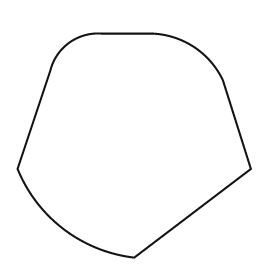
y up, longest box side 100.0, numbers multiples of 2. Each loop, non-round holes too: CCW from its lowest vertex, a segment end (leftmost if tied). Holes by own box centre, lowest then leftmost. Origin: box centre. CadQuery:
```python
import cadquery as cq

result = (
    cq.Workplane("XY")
    .moveTo(0.0, -48.0)
    .lineTo(50.0, -10.0)
    .lineTo(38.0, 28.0)
    .threePointArc((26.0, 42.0), (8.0, 48.0))
    .lineTo(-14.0, 48.0)
    .threePointArc((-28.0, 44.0), (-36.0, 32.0))
    .lineTo(-50.0, -10.0)
    .threePointArc((-30.0, -36.0), (0.0, -48.0))
    .close()
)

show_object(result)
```